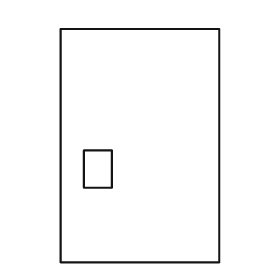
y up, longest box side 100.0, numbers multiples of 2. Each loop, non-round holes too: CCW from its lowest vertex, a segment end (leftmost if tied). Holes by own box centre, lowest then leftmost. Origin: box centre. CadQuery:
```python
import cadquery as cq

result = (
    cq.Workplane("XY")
    .moveTo(-34.0, -50.0)
    .lineTo(34.0, -50.0)
    .lineTo(34.0, 50.0)
    .lineTo(-34.0, 50.0)
    .close()
    .moveTo(-24.0, -18.0)
    .lineTo(-12.0, -18.0)
    .lineTo(-12.0, -2.0)
    .lineTo(-24.0, -2.0)
    .close()
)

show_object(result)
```